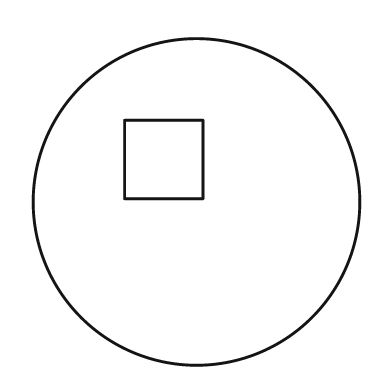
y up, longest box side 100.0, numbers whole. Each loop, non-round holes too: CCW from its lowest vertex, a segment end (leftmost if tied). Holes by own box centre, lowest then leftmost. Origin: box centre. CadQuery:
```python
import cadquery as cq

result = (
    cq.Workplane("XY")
    .moveTo(0.0, 0.0)
    .circle(50.0)
    .moveTo(-22.0, 1.0)
    .lineTo(2.0, 1.0)
    .lineTo(2.0, 25.0)
    .lineTo(-22.0, 25.0)
    .close()
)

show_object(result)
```